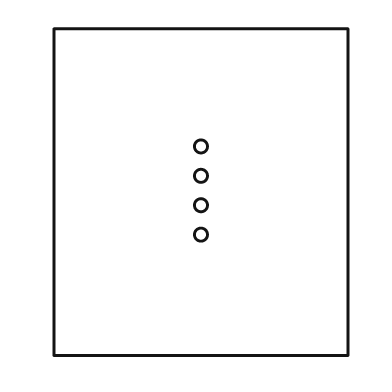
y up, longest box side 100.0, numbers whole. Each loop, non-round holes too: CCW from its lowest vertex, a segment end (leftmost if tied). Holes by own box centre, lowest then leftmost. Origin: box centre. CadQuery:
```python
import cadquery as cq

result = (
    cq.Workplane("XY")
    .moveTo(-45.0, -50.0)
    .lineTo(45.0, -50.0)
    .lineTo(45.0, 50.0)
    .lineTo(-45.0, 50.0)
    .close()
    .moveTo(0.0, -13.0)
    .circle(2.0)
    .moveTo(0.0, -4.0)
    .circle(2.0)
    .moveTo(0.0, 5.0)
    .circle(2.0)
    .moveTo(0.0, 14.0)
    .circle(2.0)
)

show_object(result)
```